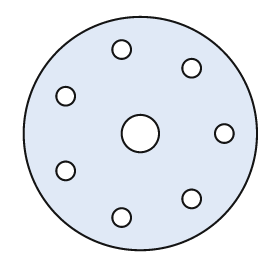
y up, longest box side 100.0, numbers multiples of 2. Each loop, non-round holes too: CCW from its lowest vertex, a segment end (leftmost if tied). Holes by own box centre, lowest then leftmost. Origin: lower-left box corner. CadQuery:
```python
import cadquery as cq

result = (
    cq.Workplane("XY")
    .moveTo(50.0, 50.0)
    .circle(50.0)
    .moveTo(42.0, 14.0)
    .circle(4.0)
    .moveTo(72.0, 22.0)
    .circle(4.0)
    .moveTo(18.0, 34.0)
    .circle(4.0)
    .moveTo(50.0, 50.0)
    .circle(8.0)
    .moveTo(86.0, 50.0)
    .circle(4.0)
    .moveTo(18.0, 66.0)
    .circle(4.0)
    .moveTo(72.0, 78.0)
    .circle(4.0)
    .moveTo(42.0, 86.0)
    .circle(4.0)
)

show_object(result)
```